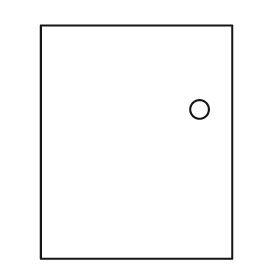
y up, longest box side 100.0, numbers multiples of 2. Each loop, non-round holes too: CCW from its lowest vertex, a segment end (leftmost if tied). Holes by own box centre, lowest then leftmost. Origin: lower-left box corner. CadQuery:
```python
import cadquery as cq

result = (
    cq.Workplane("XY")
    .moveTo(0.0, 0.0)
    .lineTo(82.0, 0.0)
    .lineTo(82.0, 100.0)
    .lineTo(0.0, 100.0)
    .close()
    .moveTo(68.0, 64.0)
    .circle(4.0)
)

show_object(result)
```